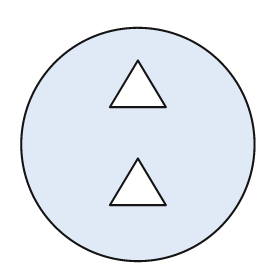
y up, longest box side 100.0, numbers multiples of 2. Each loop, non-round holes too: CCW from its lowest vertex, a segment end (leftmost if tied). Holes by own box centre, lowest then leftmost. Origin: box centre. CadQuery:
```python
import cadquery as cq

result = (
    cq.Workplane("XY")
    .moveTo(0.0, 0.0)
    .circle(50.0)
    .moveTo(-12.0, -26.0)
    .lineTo(12.0, -26.0)
    .lineTo(0.0, -6.0)
    .close()
    .moveTo(-12.0, 16.0)
    .lineTo(12.0, 16.0)
    .lineTo(0.0, 36.0)
    .close()
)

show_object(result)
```